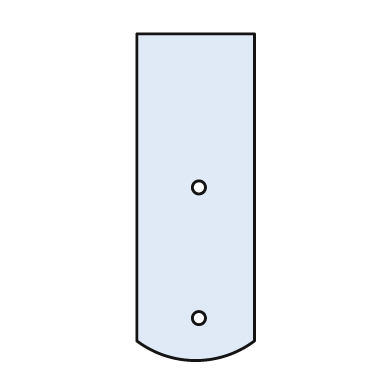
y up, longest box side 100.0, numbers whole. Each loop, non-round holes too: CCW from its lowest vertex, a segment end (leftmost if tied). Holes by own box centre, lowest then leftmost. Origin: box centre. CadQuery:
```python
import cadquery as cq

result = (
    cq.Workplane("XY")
    .moveTo(-18.0, -44.0)
    .threePointArc((0.0, -50.0), (18.0, -44.0))
    .lineTo(18.0, 50.0)
    .lineTo(-18.0, 50.0)
    .close()
    .moveTo(1.0, -37.0)
    .circle(2.0)
    .moveTo(1.0, 3.0)
    .circle(2.0)
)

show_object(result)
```